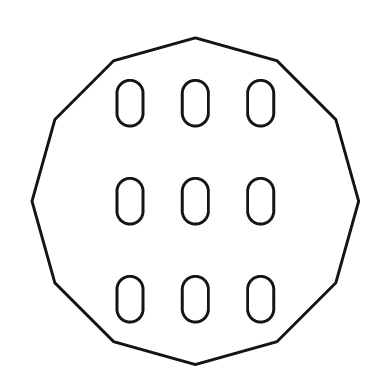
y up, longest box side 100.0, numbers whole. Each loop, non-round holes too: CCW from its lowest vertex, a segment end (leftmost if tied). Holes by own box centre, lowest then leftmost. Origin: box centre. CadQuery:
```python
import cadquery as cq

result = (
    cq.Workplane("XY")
    .moveTo(0.0, -50.0)
    .lineTo(25.0, -43.0)
    .lineTo(43.0, -25.0)
    .lineTo(50.0, 0.0)
    .lineTo(43.0, 25.0)
    .lineTo(25.0, 43.0)
    .lineTo(0.0, 50.0)
    .lineTo(-25.0, 43.0)
    .lineTo(-43.0, 25.0)
    .lineTo(-50.0, 0.0)
    .lineTo(-43.0, -25.0)
    .lineTo(-25.0, -43.0)
    .close()
    .moveTo(-24.0, -33.0)
    .threePointArc((-20.0, -37.0), (-16.0, -33.0))
    .lineTo(-16.0, -27.0)
    .threePointArc((-20.0, -23.0), (-24.0, -27.0))
    .close()
    .moveTo(-4.0, -33.0)
    .threePointArc((0.0, -37.0), (4.0, -33.0))
    .lineTo(4.0, -27.0)
    .threePointArc((0.0, -23.0), (-4.0, -27.0))
    .close()
    .moveTo(16.0, -33.0)
    .threePointArc((20.0, -37.0), (24.0, -33.0))
    .lineTo(24.0, -27.0)
    .threePointArc((20.0, -23.0), (16.0, -27.0))
    .close()
    .moveTo(-24.0, -3.0)
    .threePointArc((-20.0, -7.0), (-16.0, -3.0))
    .lineTo(-16.0, 3.0)
    .threePointArc((-20.0, 7.0), (-24.0, 3.0))
    .close()
    .moveTo(-4.0, -3.0)
    .threePointArc((0.0, -7.0), (4.0, -3.0))
    .lineTo(4.0, 3.0)
    .threePointArc((0.0, 7.0), (-4.0, 3.0))
    .close()
    .moveTo(16.0, -3.0)
    .threePointArc((20.0, -7.0), (24.0, -3.0))
    .lineTo(24.0, 3.0)
    .threePointArc((20.0, 7.0), (16.0, 3.0))
    .close()
    .moveTo(-24.0, 27.0)
    .threePointArc((-20.0, 23.0), (-16.0, 27.0))
    .lineTo(-16.0, 33.0)
    .threePointArc((-20.0, 37.0), (-24.0, 33.0))
    .close()
    .moveTo(-4.0, 27.0)
    .threePointArc((0.0, 23.0), (4.0, 27.0))
    .lineTo(4.0, 33.0)
    .threePointArc((0.0, 37.0), (-4.0, 33.0))
    .close()
    .moveTo(16.0, 27.0)
    .threePointArc((20.0, 23.0), (24.0, 27.0))
    .lineTo(24.0, 33.0)
    .threePointArc((20.0, 37.0), (16.0, 33.0))
    .close()
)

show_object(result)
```